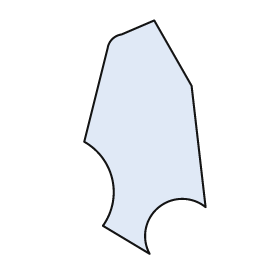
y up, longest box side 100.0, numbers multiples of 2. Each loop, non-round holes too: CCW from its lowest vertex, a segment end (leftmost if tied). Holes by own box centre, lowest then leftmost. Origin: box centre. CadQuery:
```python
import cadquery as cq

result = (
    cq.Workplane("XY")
    .moveTo(2.0, -50.0)
    .threePointArc((6.0, -30.0), (26.0, -30.0))
    .lineTo(20.0, 22.0)
    .lineTo(4.0, 50.0)
    .lineTo(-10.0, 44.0)
    .threePointArc((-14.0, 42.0), (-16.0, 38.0))
    .lineTo(-26.0, -2.0)
    .threePointArc((-14.0, -18.0), (-18.0, -38.0))
    .close()
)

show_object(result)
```